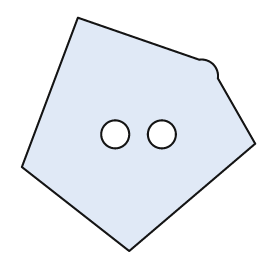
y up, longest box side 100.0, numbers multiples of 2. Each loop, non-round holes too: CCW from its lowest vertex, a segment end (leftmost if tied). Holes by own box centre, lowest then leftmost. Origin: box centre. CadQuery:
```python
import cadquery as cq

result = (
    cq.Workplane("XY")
    .moveTo(-4.0, -50.0)
    .lineTo(50.0, -4.0)
    .lineTo(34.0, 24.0)
    .threePointArc((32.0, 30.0), (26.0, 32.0))
    .lineTo(-26.0, 50.0)
    .lineTo(-50.0, -14.0)
    .close()
    .moveTo(-10.0, 0.0)
    .circle(6.0)
    .moveTo(10.0, 0.0)
    .circle(6.0)
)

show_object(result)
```